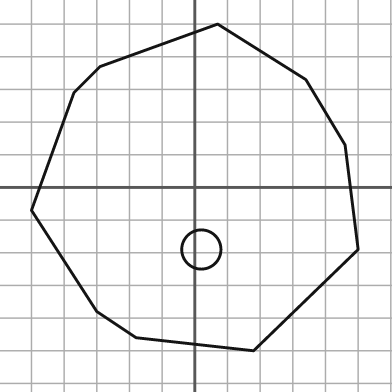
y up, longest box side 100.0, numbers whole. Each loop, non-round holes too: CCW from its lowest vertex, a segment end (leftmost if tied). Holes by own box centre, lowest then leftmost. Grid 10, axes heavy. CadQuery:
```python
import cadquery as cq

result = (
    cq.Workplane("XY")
    .moveTo(18.0, -50.0)
    .lineTo(50.0, -19.0)
    .lineTo(46.0, 13.0)
    .lineTo(34.0, 33.0)
    .lineTo(7.0, 50.0)
    .lineTo(-29.0, 37.0)
    .lineTo(-37.0, 29.0)
    .lineTo(-50.0, -7.0)
    .lineTo(-30.0, -38.0)
    .lineTo(-18.0, -46.0)
    .close()
    .moveTo(2.0, -19.0)
    .circle(6.0)
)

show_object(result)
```